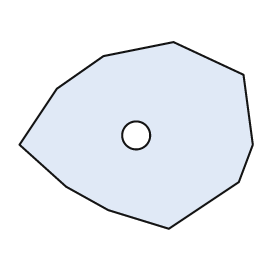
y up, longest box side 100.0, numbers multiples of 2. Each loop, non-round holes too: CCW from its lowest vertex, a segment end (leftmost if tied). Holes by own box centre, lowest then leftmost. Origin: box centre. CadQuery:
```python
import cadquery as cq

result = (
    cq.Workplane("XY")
    .moveTo(14.0, -40.0)
    .lineTo(44.0, -20.0)
    .lineTo(50.0, -4.0)
    .lineTo(46.0, 26.0)
    .lineTo(16.0, 40.0)
    .lineTo(-14.0, 34.0)
    .lineTo(-34.0, 20.0)
    .lineTo(-50.0, -4.0)
    .lineTo(-30.0, -22.0)
    .lineTo(-12.0, -32.0)
    .close()
    .moveTo(0.0, 0.0)
    .circle(6.0)
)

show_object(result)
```